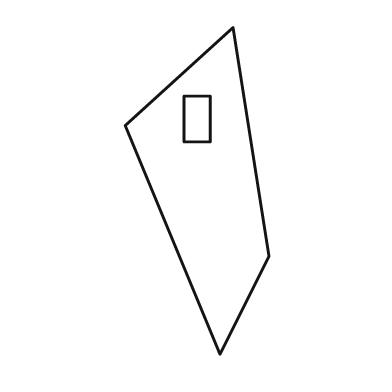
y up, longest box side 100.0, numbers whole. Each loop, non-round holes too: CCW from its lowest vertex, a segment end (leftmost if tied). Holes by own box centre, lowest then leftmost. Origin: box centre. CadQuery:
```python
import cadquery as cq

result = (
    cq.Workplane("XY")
    .moveTo(7.0, -50.0)
    .lineTo(22.0, -20.0)
    .lineTo(11.0, 50.0)
    .lineTo(-22.0, 20.0)
    .close()
    .moveTo(-4.0, 15.0)
    .lineTo(4.0, 15.0)
    .lineTo(4.0, 29.0)
    .lineTo(-4.0, 29.0)
    .close()
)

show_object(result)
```